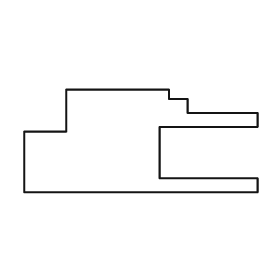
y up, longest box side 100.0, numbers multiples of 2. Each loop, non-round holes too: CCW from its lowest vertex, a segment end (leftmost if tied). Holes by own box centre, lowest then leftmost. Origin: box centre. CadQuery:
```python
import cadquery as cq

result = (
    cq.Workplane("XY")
    .moveTo(-50.0, -22.0)
    .lineTo(50.0, -22.0)
    .lineTo(50.0, -16.0)
    .lineTo(8.0, -16.0)
    .lineTo(8.0, 6.0)
    .lineTo(50.0, 6.0)
    .lineTo(50.0, 12.0)
    .lineTo(20.0, 12.0)
    .lineTo(20.0, 18.0)
    .lineTo(12.0, 18.0)
    .lineTo(12.0, 22.0)
    .lineTo(-32.0, 22.0)
    .lineTo(-32.0, 4.0)
    .lineTo(-50.0, 4.0)
    .close()
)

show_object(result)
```